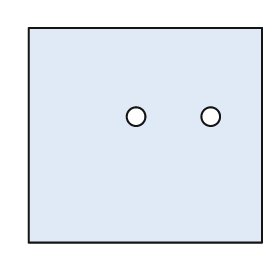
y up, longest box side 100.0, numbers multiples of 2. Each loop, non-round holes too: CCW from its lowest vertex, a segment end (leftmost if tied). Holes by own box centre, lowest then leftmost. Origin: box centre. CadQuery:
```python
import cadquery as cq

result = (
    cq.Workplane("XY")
    .moveTo(-50.0, -46.0)
    .lineTo(50.0, -46.0)
    .lineTo(50.0, 46.0)
    .lineTo(-50.0, 46.0)
    .close()
    .moveTo(-4.0, 8.0)
    .circle(4.0)
    .moveTo(28.0, 8.0)
    .circle(4.0)
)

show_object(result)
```